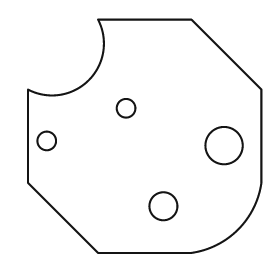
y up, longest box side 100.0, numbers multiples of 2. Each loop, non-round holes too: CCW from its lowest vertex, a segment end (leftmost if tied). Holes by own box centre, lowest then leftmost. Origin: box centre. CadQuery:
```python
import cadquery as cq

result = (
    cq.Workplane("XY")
    .moveTo(-20.0, -50.0)
    .lineTo(20.0, -50.0)
    .threePointArc((40.0, -40.0), (50.0, -20.0))
    .lineTo(50.0, 20.0)
    .lineTo(20.0, 50.0)
    .lineTo(-20.0, 50.0)
    .threePointArc((-24.0, 24.0), (-50.0, 20.0))
    .lineTo(-50.0, -20.0)
    .close()
    .moveTo(8.0, -30.0)
    .circle(6.0)
    .moveTo(34.0, -4.0)
    .circle(8.0)
    .moveTo(-42.0, -2.0)
    .circle(4.0)
    .moveTo(-8.0, 12.0)
    .circle(4.0)
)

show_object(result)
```